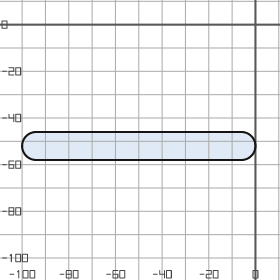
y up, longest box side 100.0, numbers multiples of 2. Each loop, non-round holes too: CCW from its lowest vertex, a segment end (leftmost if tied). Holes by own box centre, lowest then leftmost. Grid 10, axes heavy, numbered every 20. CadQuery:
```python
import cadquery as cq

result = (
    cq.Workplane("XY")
    .moveTo(-94.0, -58.0)
    .lineTo(-6.0, -58.0)
    .threePointArc((0.0, -52.0), (-6.0, -46.0))
    .lineTo(-94.0, -46.0)
    .threePointArc((-100.0, -52.0), (-94.0, -58.0))
    .close()
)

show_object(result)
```